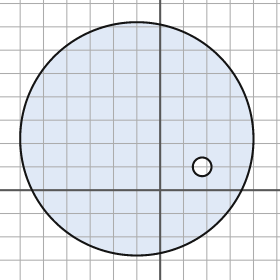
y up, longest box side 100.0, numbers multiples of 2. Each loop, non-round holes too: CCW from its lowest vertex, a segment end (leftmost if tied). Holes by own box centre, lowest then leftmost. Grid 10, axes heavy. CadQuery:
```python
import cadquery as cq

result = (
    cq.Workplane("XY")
    .moveTo(-10.0, 22.0)
    .circle(50.0)
    .moveTo(18.0, 10.0)
    .circle(4.0)
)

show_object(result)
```